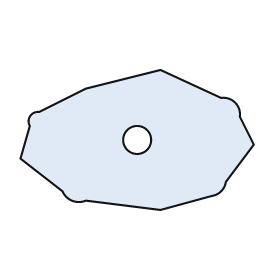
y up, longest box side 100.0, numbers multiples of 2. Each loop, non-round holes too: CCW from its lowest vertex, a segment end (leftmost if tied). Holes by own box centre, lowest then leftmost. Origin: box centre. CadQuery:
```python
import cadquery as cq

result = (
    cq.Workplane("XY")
    .moveTo(10.0, -30.0)
    .lineTo(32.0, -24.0)
    .threePointArc((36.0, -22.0), (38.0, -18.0))
    .lineTo(50.0, -2.0)
    .lineTo(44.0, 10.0)
    .threePointArc((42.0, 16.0), (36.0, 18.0))
    .lineTo(10.0, 30.0)
    .lineTo(-22.0, 22.0)
    .lineTo(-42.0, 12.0)
    .threePointArc((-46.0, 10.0), (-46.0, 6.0))
    .lineTo(-50.0, -8.0)
    .lineTo(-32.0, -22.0)
    .threePointArc((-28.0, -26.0), (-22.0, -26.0))
    .close()
    .moveTo(0.0, 0.0)
    .circle(6.0)
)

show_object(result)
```